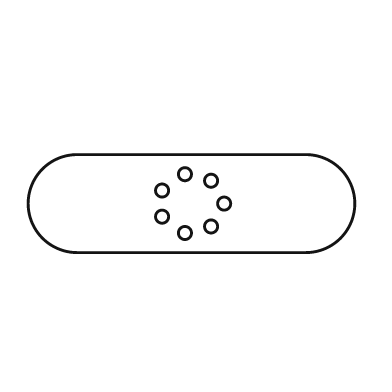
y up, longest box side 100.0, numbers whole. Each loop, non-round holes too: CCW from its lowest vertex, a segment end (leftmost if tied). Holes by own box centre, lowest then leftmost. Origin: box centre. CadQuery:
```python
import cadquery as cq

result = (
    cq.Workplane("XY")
    .moveTo(-35.0, -15.0)
    .lineTo(35.0, -15.0)
    .threePointArc((50.0, 0.0), (35.0, 15.0))
    .lineTo(-35.0, 15.0)
    .threePointArc((-50.0, 0.0), (-35.0, -15.0))
    .close()
    .moveTo(-2.0, -9.0)
    .circle(2.0)
    .moveTo(6.0, -7.0)
    .circle(2.0)
    .moveTo(-9.0, -4.0)
    .circle(2.0)
    .moveTo(10.0, 0.0)
    .circle(2.0)
    .moveTo(-9.0, 4.0)
    .circle(2.0)
    .moveTo(6.0, 7.0)
    .circle(2.0)
    .moveTo(-2.0, 9.0)
    .circle(2.0)
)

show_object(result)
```